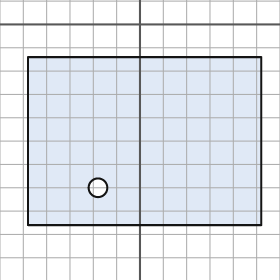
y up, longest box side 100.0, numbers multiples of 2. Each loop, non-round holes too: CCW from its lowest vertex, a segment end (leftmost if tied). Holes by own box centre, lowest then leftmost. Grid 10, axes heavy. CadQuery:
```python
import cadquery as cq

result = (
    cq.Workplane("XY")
    .moveTo(-48.0, -86.0)
    .lineTo(52.0, -86.0)
    .lineTo(52.0, -14.0)
    .lineTo(-48.0, -14.0)
    .close()
    .moveTo(-18.0, -70.0)
    .circle(4.0)
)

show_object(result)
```